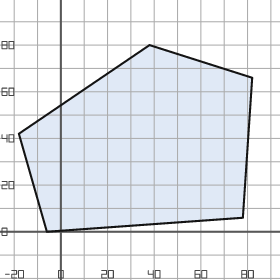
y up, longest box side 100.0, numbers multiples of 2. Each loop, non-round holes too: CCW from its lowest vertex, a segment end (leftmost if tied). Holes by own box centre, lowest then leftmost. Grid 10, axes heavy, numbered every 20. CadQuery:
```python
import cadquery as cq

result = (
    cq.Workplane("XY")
    .moveTo(-6.0, 0.0)
    .lineTo(78.0, 6.0)
    .lineTo(82.0, 66.0)
    .lineTo(38.0, 80.0)
    .lineTo(-18.0, 42.0)
    .close()
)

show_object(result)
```